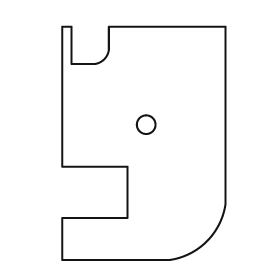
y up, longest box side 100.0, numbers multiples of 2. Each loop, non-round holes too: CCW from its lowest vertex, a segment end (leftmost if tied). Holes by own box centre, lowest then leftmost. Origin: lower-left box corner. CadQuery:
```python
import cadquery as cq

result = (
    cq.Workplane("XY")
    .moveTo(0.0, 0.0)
    .lineTo(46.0, 0.0)
    .threePointArc((62.0, 8.0), (70.0, 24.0))
    .lineTo(70.0, 100.0)
    .lineTo(20.0, 100.0)
    .lineTo(20.0, 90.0)
    .threePointArc((18.0, 86.0), (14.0, 84.0))
    .lineTo(4.0, 84.0)
    .lineTo(4.0, 100.0)
    .lineTo(0.0, 100.0)
    .lineTo(0.0, 40.0)
    .lineTo(28.0, 40.0)
    .lineTo(28.0, 18.0)
    .lineTo(0.0, 18.0)
    .close()
    .moveTo(36.0, 58.0)
    .circle(4.0)
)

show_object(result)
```